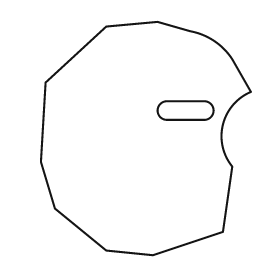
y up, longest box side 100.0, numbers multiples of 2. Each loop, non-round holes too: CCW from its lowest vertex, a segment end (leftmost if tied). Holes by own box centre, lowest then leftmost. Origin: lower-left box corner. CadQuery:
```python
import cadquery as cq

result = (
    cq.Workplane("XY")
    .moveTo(48.0, 0.0)
    .lineTo(78.0, 10.0)
    .lineTo(82.0, 38.0)
    .threePointArc((78.0, 56.0), (90.0, 70.0))
    .lineTo(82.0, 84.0)
    .threePointArc((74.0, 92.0), (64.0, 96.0))
    .lineTo(50.0, 100.0)
    .lineTo(28.0, 98.0)
    .lineTo(2.0, 74.0)
    .lineTo(0.0, 40.0)
    .lineTo(6.0, 20.0)
    .lineTo(28.0, 2.0)
    .close()
    .moveTo(54.0, 58.0)
    .lineTo(70.0, 58.0)
    .threePointArc((74.0, 62.0), (70.0, 66.0))
    .lineTo(54.0, 66.0)
    .threePointArc((50.0, 62.0), (54.0, 58.0))
    .close()
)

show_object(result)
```